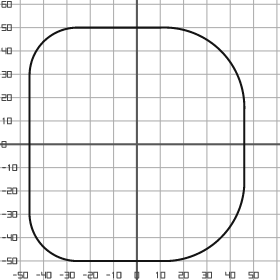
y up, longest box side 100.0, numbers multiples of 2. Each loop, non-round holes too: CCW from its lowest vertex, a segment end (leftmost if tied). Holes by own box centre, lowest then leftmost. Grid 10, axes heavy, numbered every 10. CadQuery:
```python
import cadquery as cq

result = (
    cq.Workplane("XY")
    .moveTo(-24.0, -50.0)
    .lineTo(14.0, -50.0)
    .threePointArc((36.0, -40.0), (46.0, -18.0))
    .lineTo(46.0, 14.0)
    .threePointArc((36.0, 40.0), (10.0, 50.0))
    .lineTo(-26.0, 50.0)
    .threePointArc((-40.0, 44.0), (-46.0, 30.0))
    .lineTo(-46.0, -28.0)
    .threePointArc((-40.0, -44.0), (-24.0, -50.0))
    .close()
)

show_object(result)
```